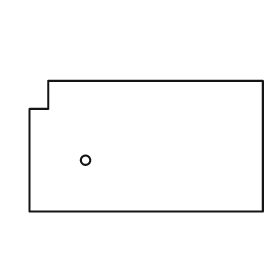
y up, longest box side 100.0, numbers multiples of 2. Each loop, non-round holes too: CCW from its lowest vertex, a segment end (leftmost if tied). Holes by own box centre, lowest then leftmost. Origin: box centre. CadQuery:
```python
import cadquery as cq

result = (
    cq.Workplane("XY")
    .moveTo(-50.0, -28.0)
    .lineTo(50.0, -28.0)
    .lineTo(50.0, 28.0)
    .lineTo(-42.0, 28.0)
    .lineTo(-42.0, 16.0)
    .lineTo(-50.0, 16.0)
    .close()
    .moveTo(-26.0, -6.0)
    .circle(2.0)
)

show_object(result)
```